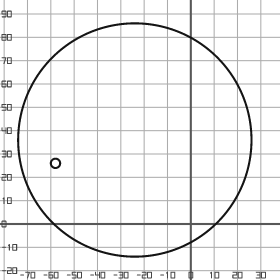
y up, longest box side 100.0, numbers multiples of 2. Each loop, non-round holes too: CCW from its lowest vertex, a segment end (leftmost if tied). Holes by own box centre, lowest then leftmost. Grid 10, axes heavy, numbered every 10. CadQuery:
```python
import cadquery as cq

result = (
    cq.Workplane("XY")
    .moveTo(-24.0, 36.0)
    .circle(50.0)
    .moveTo(-58.0, 26.0)
    .circle(2.0)
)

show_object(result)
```